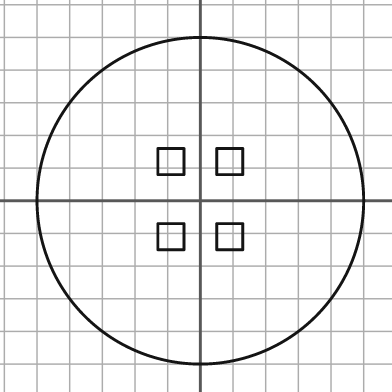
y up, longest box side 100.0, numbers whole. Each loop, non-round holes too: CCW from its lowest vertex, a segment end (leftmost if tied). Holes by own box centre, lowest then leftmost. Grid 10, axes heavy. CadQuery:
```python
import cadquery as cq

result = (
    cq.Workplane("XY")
    .moveTo(0.0, 0.0)
    .circle(50.0)
    .moveTo(-13.0, -15.0)
    .lineTo(-5.0, -15.0)
    .lineTo(-5.0, -7.0)
    .lineTo(-13.0, -7.0)
    .close()
    .moveTo(5.0, -15.0)
    .lineTo(13.0, -15.0)
    .lineTo(13.0, -7.0)
    .lineTo(5.0, -7.0)
    .close()
    .moveTo(-13.0, 8.0)
    .lineTo(-5.0, 8.0)
    .lineTo(-5.0, 16.0)
    .lineTo(-13.0, 16.0)
    .close()
    .moveTo(5.0, 8.0)
    .lineTo(13.0, 8.0)
    .lineTo(13.0, 16.0)
    .lineTo(5.0, 16.0)
    .close()
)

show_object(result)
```